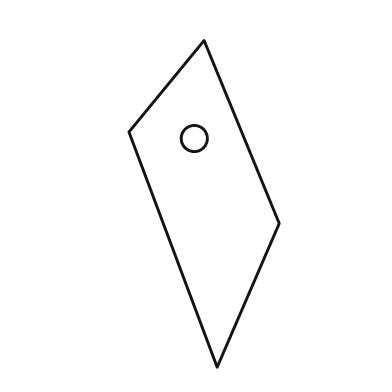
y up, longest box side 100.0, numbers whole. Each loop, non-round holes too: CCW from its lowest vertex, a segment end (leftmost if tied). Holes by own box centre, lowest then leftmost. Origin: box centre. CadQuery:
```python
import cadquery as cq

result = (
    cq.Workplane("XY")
    .moveTo(4.0, -50.0)
    .lineTo(23.0, -6.0)
    .lineTo(0.0, 50.0)
    .lineTo(-23.0, 22.0)
    .close()
    .moveTo(-3.0, 20.0)
    .circle(4.0)
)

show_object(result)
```